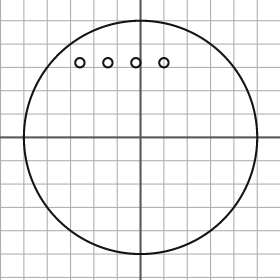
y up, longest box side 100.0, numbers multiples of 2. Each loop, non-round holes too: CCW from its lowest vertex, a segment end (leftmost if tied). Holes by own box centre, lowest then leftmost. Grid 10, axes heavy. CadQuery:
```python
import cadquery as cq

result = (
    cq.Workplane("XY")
    .moveTo(0.0, 0.0)
    .circle(50.0)
    .moveTo(-26.0, 32.0)
    .circle(2.0)
    .moveTo(-14.0, 32.0)
    .circle(2.0)
    .moveTo(-2.0, 32.0)
    .circle(2.0)
    .moveTo(10.0, 32.0)
    .circle(2.0)
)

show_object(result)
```